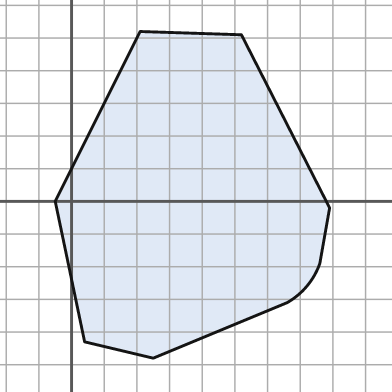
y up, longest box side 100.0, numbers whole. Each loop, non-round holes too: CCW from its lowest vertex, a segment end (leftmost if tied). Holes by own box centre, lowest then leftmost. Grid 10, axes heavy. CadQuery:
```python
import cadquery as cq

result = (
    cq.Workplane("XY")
    .moveTo(25.0, -48.0)
    .lineTo(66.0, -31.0)
    .threePointArc((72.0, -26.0), (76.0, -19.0))
    .lineTo(79.0, -2.0)
    .lineTo(52.0, 51.0)
    .lineTo(21.0, 52.0)
    .lineTo(-5.0, 0.0)
    .lineTo(4.0, -43.0)
    .close()
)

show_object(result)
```